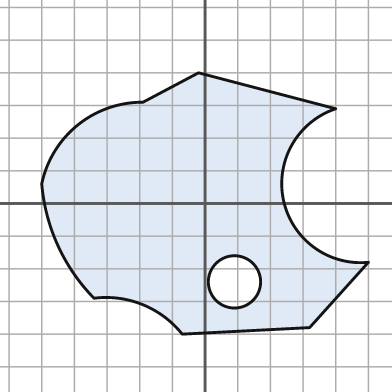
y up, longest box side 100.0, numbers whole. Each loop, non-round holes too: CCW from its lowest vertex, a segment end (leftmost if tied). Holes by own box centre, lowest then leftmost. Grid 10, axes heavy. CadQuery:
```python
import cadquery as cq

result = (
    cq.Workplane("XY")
    .moveTo(-7.0, -40.0)
    .lineTo(32.0, -38.0)
    .lineTo(50.0, -18.0)
    .threePointArc((24.0, 1.0), (40.0, 29.0))
    .lineTo(-2.0, 40.0)
    .lineTo(-19.0, 31.0)
    .threePointArc((-39.0, 24.0), (-50.0, 6.0))
    .threePointArc((-45.0, -13.0), (-34.0, -29.0))
    .threePointArc((-19.0, -31.0), (-7.0, -40.0))
    .close()
    .moveTo(9.0, -24.0)
    .circle(8.0)
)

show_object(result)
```